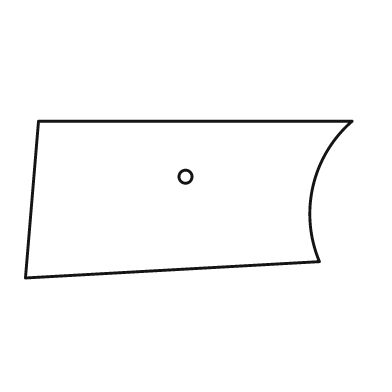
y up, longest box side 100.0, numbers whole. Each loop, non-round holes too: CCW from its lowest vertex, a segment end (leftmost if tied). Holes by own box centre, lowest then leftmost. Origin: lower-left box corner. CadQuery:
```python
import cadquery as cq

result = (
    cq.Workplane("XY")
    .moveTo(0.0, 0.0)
    .lineTo(90.0, 5.0)
    .threePointArc((88.0, 28.0), (100.0, 48.0))
    .lineTo(4.0, 48.0)
    .close()
    .moveTo(49.0, 31.0)
    .circle(2.0)
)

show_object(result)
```